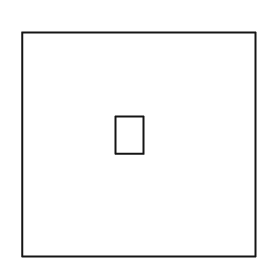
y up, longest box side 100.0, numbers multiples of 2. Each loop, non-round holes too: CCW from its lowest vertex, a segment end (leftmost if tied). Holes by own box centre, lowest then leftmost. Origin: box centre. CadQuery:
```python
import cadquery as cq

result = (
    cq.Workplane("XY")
    .moveTo(-50.0, -48.0)
    .lineTo(50.0, -48.0)
    .lineTo(50.0, 48.0)
    .lineTo(-50.0, 48.0)
    .close()
    .moveTo(-10.0, -4.0)
    .lineTo(2.0, -4.0)
    .lineTo(2.0, 12.0)
    .lineTo(-10.0, 12.0)
    .close()
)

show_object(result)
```